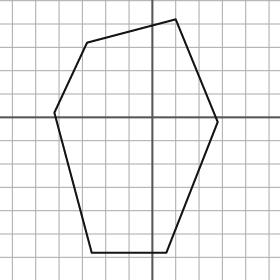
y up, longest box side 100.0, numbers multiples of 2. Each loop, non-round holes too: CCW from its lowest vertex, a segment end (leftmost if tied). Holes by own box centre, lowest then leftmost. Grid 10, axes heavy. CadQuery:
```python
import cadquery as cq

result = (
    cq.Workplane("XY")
    .moveTo(-26.0, -58.0)
    .lineTo(6.0, -58.0)
    .lineTo(28.0, -2.0)
    .lineTo(10.0, 42.0)
    .lineTo(-28.0, 32.0)
    .lineTo(-42.0, 2.0)
    .close()
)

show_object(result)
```